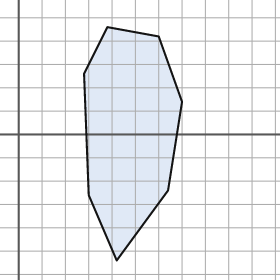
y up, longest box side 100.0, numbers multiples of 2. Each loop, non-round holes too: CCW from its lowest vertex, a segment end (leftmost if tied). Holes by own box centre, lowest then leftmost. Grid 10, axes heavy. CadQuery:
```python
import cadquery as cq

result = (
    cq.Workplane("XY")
    .moveTo(42.0, -54.0)
    .lineTo(64.0, -24.0)
    .lineTo(70.0, 14.0)
    .lineTo(60.0, 42.0)
    .lineTo(38.0, 46.0)
    .lineTo(28.0, 26.0)
    .lineTo(30.0, -26.0)
    .close()
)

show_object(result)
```